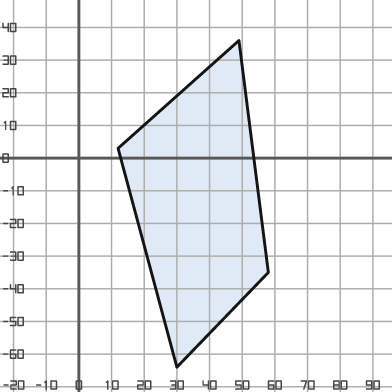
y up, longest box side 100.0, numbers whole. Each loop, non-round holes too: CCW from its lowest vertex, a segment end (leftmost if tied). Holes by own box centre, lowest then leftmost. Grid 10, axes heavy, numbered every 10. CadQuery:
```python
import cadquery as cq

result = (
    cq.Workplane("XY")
    .moveTo(30.0, -64.0)
    .lineTo(58.0, -35.0)
    .lineTo(49.0, 36.0)
    .lineTo(12.0, 3.0)
    .close()
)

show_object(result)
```